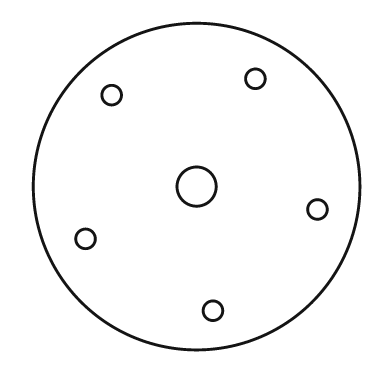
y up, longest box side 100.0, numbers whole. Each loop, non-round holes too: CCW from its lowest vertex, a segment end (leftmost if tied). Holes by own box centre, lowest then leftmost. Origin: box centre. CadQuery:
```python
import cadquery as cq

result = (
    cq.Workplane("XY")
    .moveTo(0.0, 0.0)
    .circle(50.0)
    .moveTo(5.0, -38.0)
    .circle(3.0)
    .moveTo(-34.0, -16.0)
    .circle(3.0)
    .moveTo(37.0, -7.0)
    .circle(3.0)
    .moveTo(0.0, 0.0)
    .circle(6.0)
    .moveTo(-26.0, 28.0)
    .circle(3.0)
    .moveTo(18.0, 33.0)
    .circle(3.0)
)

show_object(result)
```